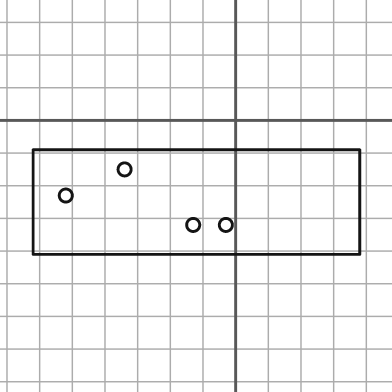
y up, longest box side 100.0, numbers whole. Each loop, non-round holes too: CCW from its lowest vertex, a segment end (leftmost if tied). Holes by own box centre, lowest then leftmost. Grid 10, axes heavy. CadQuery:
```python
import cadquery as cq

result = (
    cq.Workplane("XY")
    .moveTo(-62.0, -41.0)
    .lineTo(38.0, -41.0)
    .lineTo(38.0, -9.0)
    .lineTo(-62.0, -9.0)
    .close()
    .moveTo(-13.0, -32.0)
    .circle(2.0)
    .moveTo(-3.0, -32.0)
    .circle(2.0)
    .moveTo(-52.0, -23.0)
    .circle(2.0)
    .moveTo(-34.0, -15.0)
    .circle(2.0)
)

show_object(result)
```